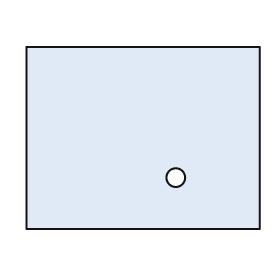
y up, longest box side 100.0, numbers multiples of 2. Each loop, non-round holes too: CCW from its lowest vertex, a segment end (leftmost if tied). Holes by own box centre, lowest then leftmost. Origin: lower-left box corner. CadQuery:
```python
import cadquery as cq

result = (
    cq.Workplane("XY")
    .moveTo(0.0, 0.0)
    .lineTo(100.0, 0.0)
    .lineTo(100.0, 78.0)
    .lineTo(0.0, 78.0)
    .close()
    .moveTo(64.0, 22.0)
    .circle(4.0)
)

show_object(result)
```